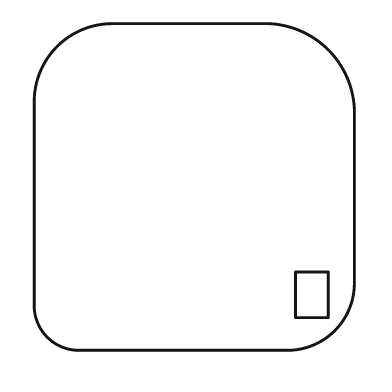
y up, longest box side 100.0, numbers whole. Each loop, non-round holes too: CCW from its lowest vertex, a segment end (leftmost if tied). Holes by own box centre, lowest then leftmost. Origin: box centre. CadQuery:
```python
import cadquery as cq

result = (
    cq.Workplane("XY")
    .moveTo(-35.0, -50.0)
    .lineTo(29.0, -50.0)
    .threePointArc((43.0, -44.0), (49.0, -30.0))
    .lineTo(49.0, 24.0)
    .threePointArc((41.0, 42.0), (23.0, 50.0))
    .lineTo(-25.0, 50.0)
    .threePointArc((-42.0, 43.0), (-49.0, 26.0))
    .lineTo(-49.0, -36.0)
    .threePointArc((-45.0, -46.0), (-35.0, -50.0))
    .close()
    .moveTo(31.0, -40.0)
    .lineTo(41.0, -40.0)
    .lineTo(41.0, -26.0)
    .lineTo(31.0, -26.0)
    .close()
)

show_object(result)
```